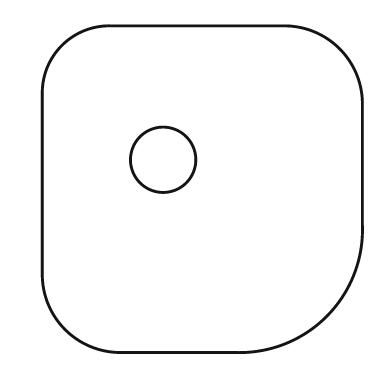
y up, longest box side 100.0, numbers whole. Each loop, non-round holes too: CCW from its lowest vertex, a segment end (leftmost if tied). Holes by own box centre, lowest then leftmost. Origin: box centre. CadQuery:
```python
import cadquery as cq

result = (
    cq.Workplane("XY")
    .moveTo(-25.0, -50.0)
    .lineTo(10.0, -50.0)
    .threePointArc((38.0, -39.0), (49.0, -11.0))
    .lineTo(49.0, 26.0)
    .threePointArc((42.0, 43.0), (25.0, 50.0))
    .lineTo(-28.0, 50.0)
    .threePointArc((-43.0, 44.0), (-49.0, 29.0))
    .lineTo(-49.0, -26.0)
    .threePointArc((-42.0, -43.0), (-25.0, -50.0))
    .close()
    .moveTo(-12.0, 9.0)
    .circle(10.0)
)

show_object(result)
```